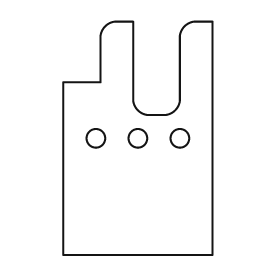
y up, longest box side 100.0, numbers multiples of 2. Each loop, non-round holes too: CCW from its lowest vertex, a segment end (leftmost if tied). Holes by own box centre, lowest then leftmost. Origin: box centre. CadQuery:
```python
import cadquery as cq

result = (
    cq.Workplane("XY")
    .moveTo(-32.0, -50.0)
    .lineTo(32.0, -50.0)
    .lineTo(32.0, 50.0)
    .lineTo(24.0, 50.0)
    .threePointArc((20.0, 48.0), (18.0, 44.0))
    .lineTo(18.0, 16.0)
    .threePointArc((16.0, 12.0), (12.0, 10.0))
    .lineTo(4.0, 10.0)
    .threePointArc((0.0, 12.0), (-2.0, 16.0))
    .lineTo(-2.0, 50.0)
    .lineTo(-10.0, 50.0)
    .threePointArc((-14.0, 48.0), (-16.0, 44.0))
    .lineTo(-16.0, 24.0)
    .lineTo(-32.0, 24.0)
    .close()
    .moveTo(-18.0, 0.0)
    .circle(4.0)
    .moveTo(0.0, 0.0)
    .circle(4.0)
    .moveTo(18.0, 0.0)
    .circle(4.0)
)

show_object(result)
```